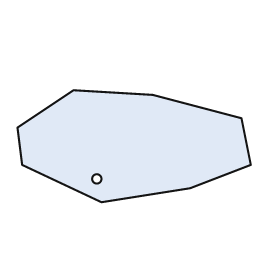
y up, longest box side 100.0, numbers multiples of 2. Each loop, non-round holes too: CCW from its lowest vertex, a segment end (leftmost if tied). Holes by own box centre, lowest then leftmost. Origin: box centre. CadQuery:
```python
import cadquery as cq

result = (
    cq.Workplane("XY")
    .moveTo(-14.0, -24.0)
    .lineTo(24.0, -18.0)
    .lineTo(50.0, -8.0)
    .lineTo(46.0, 12.0)
    .lineTo(8.0, 22.0)
    .lineTo(-26.0, 24.0)
    .lineTo(-50.0, 8.0)
    .lineTo(-48.0, -8.0)
    .close()
    .moveTo(-16.0, -14.0)
    .circle(2.0)
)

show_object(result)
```